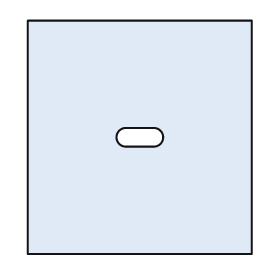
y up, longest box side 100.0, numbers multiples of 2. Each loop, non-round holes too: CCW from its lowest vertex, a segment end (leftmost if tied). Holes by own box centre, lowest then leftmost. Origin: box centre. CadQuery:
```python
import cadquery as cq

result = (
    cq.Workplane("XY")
    .moveTo(-48.0, -50.0)
    .lineTo(48.0, -50.0)
    .lineTo(48.0, 50.0)
    .lineTo(-48.0, 50.0)
    .close()
    .moveTo(-6.0, -4.0)
    .lineTo(6.0, -4.0)
    .threePointArc((10.0, 0.0), (6.0, 4.0))
    .lineTo(-6.0, 4.0)
    .threePointArc((-10.0, 0.0), (-6.0, -4.0))
    .close()
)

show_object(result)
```